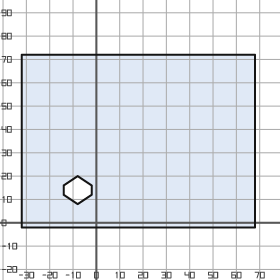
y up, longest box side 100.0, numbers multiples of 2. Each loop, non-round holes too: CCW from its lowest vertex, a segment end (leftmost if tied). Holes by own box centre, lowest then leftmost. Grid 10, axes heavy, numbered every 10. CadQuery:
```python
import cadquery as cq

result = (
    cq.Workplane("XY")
    .moveTo(-32.0, -2.0)
    .lineTo(68.0, -2.0)
    .lineTo(68.0, 72.0)
    .lineTo(-32.0, 72.0)
    .close()
    .moveTo(-8.0, 8.0)
    .lineTo(-2.0, 12.0)
    .lineTo(-2.0, 16.0)
    .lineTo(-8.0, 20.0)
    .lineTo(-14.0, 16.0)
    .lineTo(-14.0, 12.0)
    .close()
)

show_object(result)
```